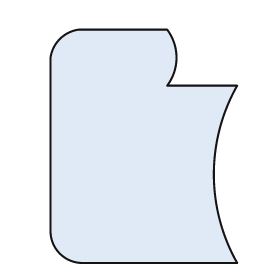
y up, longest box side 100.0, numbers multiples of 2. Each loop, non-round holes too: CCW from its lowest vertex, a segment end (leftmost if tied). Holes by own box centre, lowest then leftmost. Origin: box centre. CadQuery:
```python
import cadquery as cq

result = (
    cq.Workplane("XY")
    .moveTo(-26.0, -50.0)
    .lineTo(40.0, -50.0)
    .threePointArc((30.0, -12.0), (40.0, 26.0))
    .lineTo(10.0, 26.0)
    .threePointArc((14.0, 38.0), (10.0, 50.0))
    .lineTo(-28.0, 50.0)
    .threePointArc((-36.0, 46.0), (-40.0, 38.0))
    .lineTo(-40.0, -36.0)
    .threePointArc((-36.0, -46.0), (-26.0, -50.0))
    .close()
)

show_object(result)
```